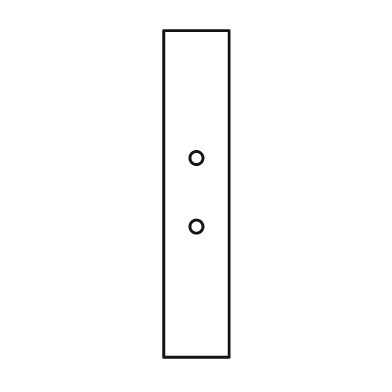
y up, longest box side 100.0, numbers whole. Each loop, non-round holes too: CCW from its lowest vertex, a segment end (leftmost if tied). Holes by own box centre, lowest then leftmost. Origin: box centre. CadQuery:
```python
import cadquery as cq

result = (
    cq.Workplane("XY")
    .moveTo(-10.0, -50.0)
    .lineTo(10.0, -50.0)
    .lineTo(10.0, 50.0)
    .lineTo(-10.0, 50.0)
    .close()
    .moveTo(0.0, -10.0)
    .circle(2.0)
    .moveTo(0.0, 11.0)
    .circle(2.0)
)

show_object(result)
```